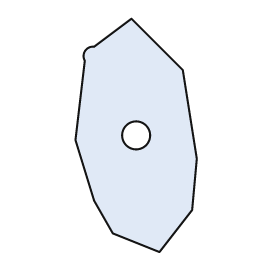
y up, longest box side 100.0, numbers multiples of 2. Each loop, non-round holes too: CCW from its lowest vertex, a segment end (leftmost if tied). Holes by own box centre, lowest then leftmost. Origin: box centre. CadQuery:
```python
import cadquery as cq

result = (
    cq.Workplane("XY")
    .moveTo(10.0, -50.0)
    .lineTo(24.0, -32.0)
    .lineTo(26.0, -10.0)
    .lineTo(20.0, 28.0)
    .lineTo(-2.0, 50.0)
    .lineTo(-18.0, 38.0)
    .threePointArc((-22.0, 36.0), (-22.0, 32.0))
    .lineTo(-26.0, -2.0)
    .lineTo(-18.0, -28.0)
    .lineTo(-10.0, -42.0)
    .close()
    .moveTo(0.0, 0.0)
    .circle(6.0)
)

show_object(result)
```